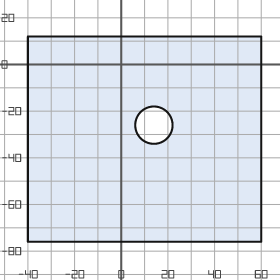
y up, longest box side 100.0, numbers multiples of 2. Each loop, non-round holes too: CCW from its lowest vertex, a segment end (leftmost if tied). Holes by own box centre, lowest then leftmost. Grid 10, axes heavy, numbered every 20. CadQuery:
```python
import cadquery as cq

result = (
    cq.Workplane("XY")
    .moveTo(-40.0, -76.0)
    .lineTo(60.0, -76.0)
    .lineTo(60.0, 12.0)
    .lineTo(-40.0, 12.0)
    .close()
    .moveTo(14.0, -26.0)
    .circle(8.0)
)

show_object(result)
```